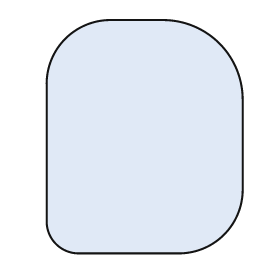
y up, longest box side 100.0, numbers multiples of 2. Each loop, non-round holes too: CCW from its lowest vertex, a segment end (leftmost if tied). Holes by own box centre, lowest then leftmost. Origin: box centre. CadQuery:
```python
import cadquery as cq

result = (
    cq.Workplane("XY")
    .moveTo(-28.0, -50.0)
    .lineTo(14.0, -50.0)
    .threePointArc((34.0, -42.0), (42.0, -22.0))
    .lineTo(42.0, 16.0)
    .threePointArc((32.0, 40.0), (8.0, 50.0))
    .lineTo(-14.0, 50.0)
    .threePointArc((-34.0, 42.0), (-42.0, 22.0))
    .lineTo(-42.0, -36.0)
    .threePointArc((-38.0, -46.0), (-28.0, -50.0))
    .close()
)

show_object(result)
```